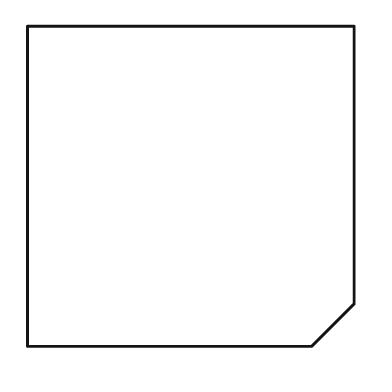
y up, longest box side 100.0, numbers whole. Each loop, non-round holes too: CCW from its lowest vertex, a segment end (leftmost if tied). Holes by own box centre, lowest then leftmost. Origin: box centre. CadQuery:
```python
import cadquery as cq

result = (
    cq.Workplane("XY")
    .moveTo(-50.0, -49.0)
    .lineTo(37.0, -49.0)
    .lineTo(50.0, -36.0)
    .lineTo(50.0, 49.0)
    .lineTo(-50.0, 49.0)
    .close()
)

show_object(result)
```